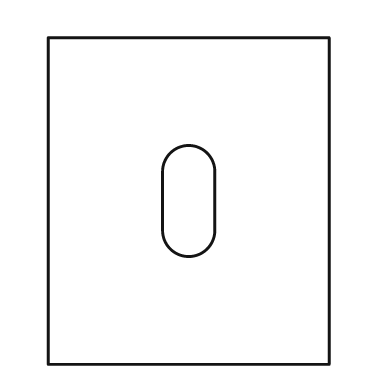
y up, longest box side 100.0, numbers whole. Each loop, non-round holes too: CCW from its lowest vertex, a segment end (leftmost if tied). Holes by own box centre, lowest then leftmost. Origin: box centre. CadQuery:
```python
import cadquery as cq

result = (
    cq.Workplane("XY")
    .moveTo(-43.0, -50.0)
    .lineTo(43.0, -50.0)
    .lineTo(43.0, 50.0)
    .lineTo(-43.0, 50.0)
    .close()
    .moveTo(-8.0, -9.0)
    .threePointArc((0.0, -17.0), (8.0, -9.0))
    .lineTo(8.0, 9.0)
    .threePointArc((0.0, 17.0), (-8.0, 9.0))
    .close()
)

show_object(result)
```